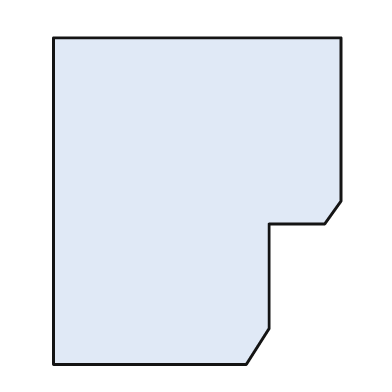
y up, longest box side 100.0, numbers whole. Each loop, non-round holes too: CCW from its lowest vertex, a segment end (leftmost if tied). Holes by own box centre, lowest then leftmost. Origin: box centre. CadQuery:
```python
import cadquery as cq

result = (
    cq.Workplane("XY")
    .moveTo(-44.0, -50.0)
    .lineTo(15.0, -50.0)
    .lineTo(22.0, -39.0)
    .lineTo(22.0, -7.0)
    .lineTo(39.0, -7.0)
    .lineTo(44.0, 0.0)
    .lineTo(44.0, 50.0)
    .lineTo(-44.0, 50.0)
    .close()
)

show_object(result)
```